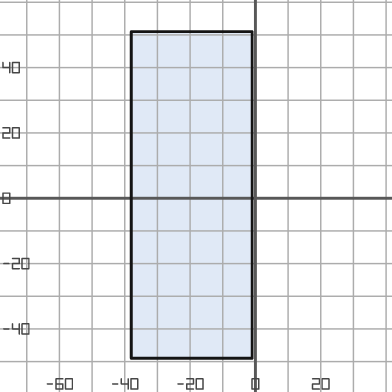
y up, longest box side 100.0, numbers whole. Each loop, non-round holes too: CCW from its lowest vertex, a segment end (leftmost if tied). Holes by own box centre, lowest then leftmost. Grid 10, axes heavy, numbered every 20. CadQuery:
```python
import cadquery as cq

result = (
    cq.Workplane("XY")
    .moveTo(-38.0, -49.0)
    .lineTo(-1.0, -49.0)
    .lineTo(-1.0, 51.0)
    .lineTo(-38.0, 51.0)
    .close()
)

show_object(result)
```